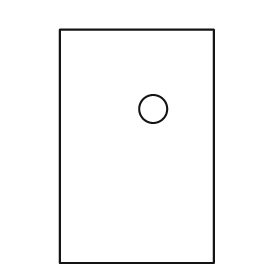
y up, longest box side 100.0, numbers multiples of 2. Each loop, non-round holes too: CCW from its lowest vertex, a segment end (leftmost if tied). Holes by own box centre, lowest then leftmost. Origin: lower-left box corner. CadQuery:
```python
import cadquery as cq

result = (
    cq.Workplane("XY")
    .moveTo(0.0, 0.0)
    .lineTo(66.0, 0.0)
    .lineTo(66.0, 100.0)
    .lineTo(0.0, 100.0)
    .close()
    .moveTo(40.0, 66.0)
    .circle(6.0)
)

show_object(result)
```